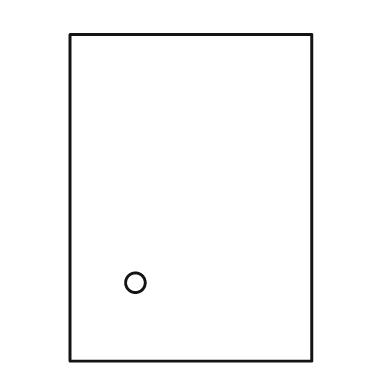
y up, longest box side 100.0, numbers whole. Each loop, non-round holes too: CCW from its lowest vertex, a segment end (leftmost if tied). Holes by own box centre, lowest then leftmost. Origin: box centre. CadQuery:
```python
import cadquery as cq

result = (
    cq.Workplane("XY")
    .moveTo(-37.0, -50.0)
    .lineTo(37.0, -50.0)
    .lineTo(37.0, 50.0)
    .lineTo(-37.0, 50.0)
    .close()
    .moveTo(-17.0, -26.0)
    .circle(3.0)
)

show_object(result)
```